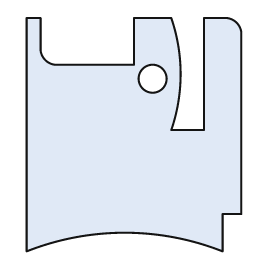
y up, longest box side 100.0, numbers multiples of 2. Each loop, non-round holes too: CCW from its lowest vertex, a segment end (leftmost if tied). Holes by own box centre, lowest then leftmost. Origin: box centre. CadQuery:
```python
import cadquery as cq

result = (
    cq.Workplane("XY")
    .moveTo(-46.0, -50.0)
    .threePointArc((-4.0, -42.0), (38.0, -50.0))
    .lineTo(38.0, -34.0)
    .lineTo(46.0, -34.0)
    .lineTo(46.0, 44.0)
    .threePointArc((44.0, 48.0), (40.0, 50.0))
    .lineTo(30.0, 50.0)
    .lineTo(30.0, 2.0)
    .lineTo(16.0, 2.0)
    .threePointArc((20.0, 26.0), (16.0, 50.0))
    .lineTo(0.0, 50.0)
    .lineTo(0.0, 30.0)
    .lineTo(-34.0, 30.0)
    .threePointArc((-38.0, 32.0), (-40.0, 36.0))
    .lineTo(-40.0, 50.0)
    .lineTo(-46.0, 50.0)
    .close()
    .moveTo(8.0, 24.0)
    .circle(6.0)
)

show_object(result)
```